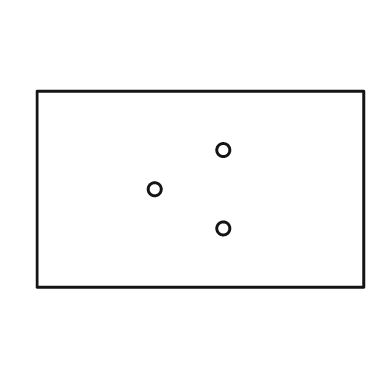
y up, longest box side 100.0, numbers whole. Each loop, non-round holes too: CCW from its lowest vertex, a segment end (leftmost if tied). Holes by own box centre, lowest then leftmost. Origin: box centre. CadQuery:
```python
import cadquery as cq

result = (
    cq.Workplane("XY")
    .moveTo(-50.0, -30.0)
    .lineTo(50.0, -30.0)
    .lineTo(50.0, 30.0)
    .lineTo(-50.0, 30.0)
    .close()
    .moveTo(7.0, -12.0)
    .circle(2.0)
    .moveTo(-14.0, 0.0)
    .circle(2.0)
    .moveTo(7.0, 12.0)
    .circle(2.0)
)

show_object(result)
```